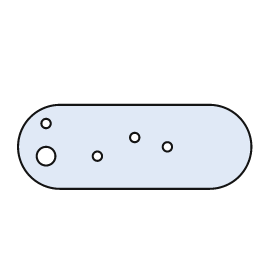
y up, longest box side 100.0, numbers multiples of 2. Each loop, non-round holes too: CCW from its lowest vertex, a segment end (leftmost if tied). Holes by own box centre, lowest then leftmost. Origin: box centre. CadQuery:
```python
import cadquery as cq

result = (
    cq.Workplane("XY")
    .moveTo(-32.0, -18.0)
    .lineTo(32.0, -18.0)
    .threePointArc((50.0, 0.0), (32.0, 18.0))
    .lineTo(-32.0, 18.0)
    .threePointArc((-50.0, 0.0), (-32.0, -18.0))
    .close()
    .moveTo(-38.0, -4.0)
    .circle(4.0)
    .moveTo(-16.0, -4.0)
    .circle(2.0)
    .moveTo(14.0, 0.0)
    .circle(2.0)
    .moveTo(0.0, 4.0)
    .circle(2.0)
    .moveTo(-38.0, 10.0)
    .circle(2.0)
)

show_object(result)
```